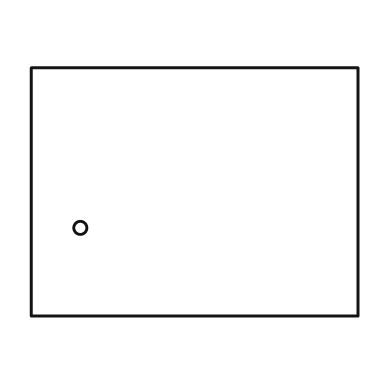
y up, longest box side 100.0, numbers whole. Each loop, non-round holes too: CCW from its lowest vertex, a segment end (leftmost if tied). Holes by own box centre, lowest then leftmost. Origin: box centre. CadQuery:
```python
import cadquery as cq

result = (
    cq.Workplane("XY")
    .moveTo(-50.0, -38.0)
    .lineTo(50.0, -38.0)
    .lineTo(50.0, 38.0)
    .lineTo(-50.0, 38.0)
    .close()
    .moveTo(-35.0, -11.0)
    .circle(2.0)
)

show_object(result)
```